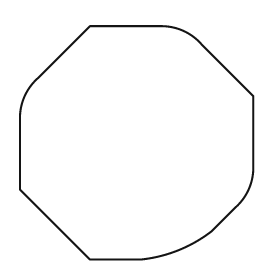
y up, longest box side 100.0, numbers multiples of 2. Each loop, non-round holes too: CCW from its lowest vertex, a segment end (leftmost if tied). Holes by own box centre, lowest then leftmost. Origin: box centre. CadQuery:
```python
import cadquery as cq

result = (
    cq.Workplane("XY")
    .moveTo(-20.0, -50.0)
    .lineTo(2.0, -50.0)
    .threePointArc((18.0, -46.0), (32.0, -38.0))
    .lineTo(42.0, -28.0)
    .threePointArc((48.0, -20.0), (50.0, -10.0))
    .lineTo(50.0, 20.0)
    .lineTo(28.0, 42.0)
    .threePointArc((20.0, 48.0), (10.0, 50.0))
    .lineTo(-20.0, 50.0)
    .lineTo(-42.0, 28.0)
    .threePointArc((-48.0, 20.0), (-50.0, 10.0))
    .lineTo(-50.0, -20.0)
    .close()
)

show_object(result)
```